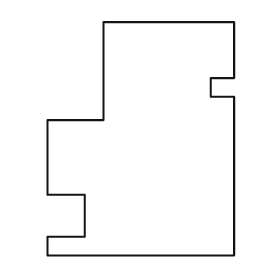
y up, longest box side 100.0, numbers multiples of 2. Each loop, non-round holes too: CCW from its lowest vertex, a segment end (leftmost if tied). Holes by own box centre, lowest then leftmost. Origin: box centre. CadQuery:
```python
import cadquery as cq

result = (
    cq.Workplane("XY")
    .moveTo(-40.0, -50.0)
    .lineTo(40.0, -50.0)
    .lineTo(40.0, 18.0)
    .lineTo(30.0, 18.0)
    .lineTo(30.0, 26.0)
    .lineTo(40.0, 26.0)
    .lineTo(40.0, 50.0)
    .lineTo(-16.0, 50.0)
    .lineTo(-16.0, 8.0)
    .lineTo(-40.0, 8.0)
    .lineTo(-40.0, -24.0)
    .lineTo(-24.0, -24.0)
    .lineTo(-24.0, -42.0)
    .lineTo(-40.0, -42.0)
    .close()
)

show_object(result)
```